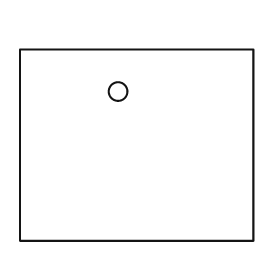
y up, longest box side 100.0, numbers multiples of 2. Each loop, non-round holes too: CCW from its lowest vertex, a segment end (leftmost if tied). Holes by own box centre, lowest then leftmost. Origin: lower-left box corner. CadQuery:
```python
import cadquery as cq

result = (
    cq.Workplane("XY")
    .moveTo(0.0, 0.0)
    .lineTo(100.0, 0.0)
    .lineTo(100.0, 82.0)
    .lineTo(0.0, 82.0)
    .close()
    .moveTo(42.0, 64.0)
    .circle(4.0)
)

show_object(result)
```